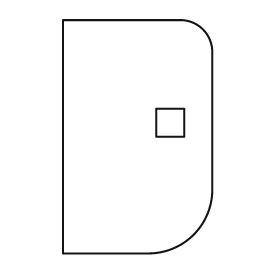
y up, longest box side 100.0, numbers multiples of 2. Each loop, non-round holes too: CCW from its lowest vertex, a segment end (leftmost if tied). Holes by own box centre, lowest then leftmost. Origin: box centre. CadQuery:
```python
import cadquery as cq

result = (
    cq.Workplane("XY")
    .moveTo(-32.0, -50.0)
    .lineTo(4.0, -50.0)
    .threePointArc((24.0, -42.0), (32.0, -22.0))
    .lineTo(32.0, 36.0)
    .threePointArc((28.0, 46.0), (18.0, 50.0))
    .lineTo(-32.0, 50.0)
    .close()
    .moveTo(8.0, 0.0)
    .lineTo(20.0, 0.0)
    .lineTo(20.0, 12.0)
    .lineTo(8.0, 12.0)
    .close()
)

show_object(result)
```